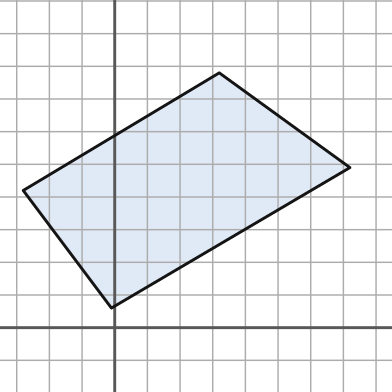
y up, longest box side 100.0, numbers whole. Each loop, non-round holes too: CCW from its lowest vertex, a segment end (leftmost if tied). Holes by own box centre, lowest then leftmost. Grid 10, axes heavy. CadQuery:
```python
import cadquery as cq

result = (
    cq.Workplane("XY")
    .moveTo(-1.0, 6.0)
    .lineTo(72.0, 49.0)
    .lineTo(32.0, 78.0)
    .lineTo(-28.0, 42.0)
    .close()
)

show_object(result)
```